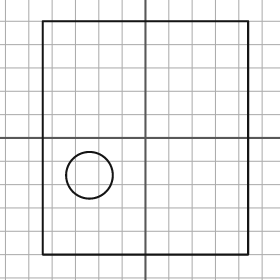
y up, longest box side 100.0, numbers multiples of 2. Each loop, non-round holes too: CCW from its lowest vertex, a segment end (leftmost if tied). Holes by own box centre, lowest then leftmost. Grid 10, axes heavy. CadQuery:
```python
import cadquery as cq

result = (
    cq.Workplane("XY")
    .moveTo(-44.0, -50.0)
    .lineTo(44.0, -50.0)
    .lineTo(44.0, 50.0)
    .lineTo(-44.0, 50.0)
    .close()
    .moveTo(-24.0, -16.0)
    .circle(10.0)
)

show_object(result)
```